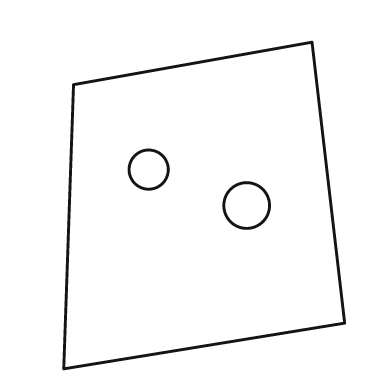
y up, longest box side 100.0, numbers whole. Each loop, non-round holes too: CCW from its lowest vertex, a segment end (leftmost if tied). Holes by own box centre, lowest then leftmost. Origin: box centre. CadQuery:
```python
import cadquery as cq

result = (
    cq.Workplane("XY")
    .moveTo(-43.0, -50.0)
    .lineTo(43.0, -36.0)
    .lineTo(33.0, 50.0)
    .lineTo(-40.0, 37.0)
    .close()
    .moveTo(13.0, 0.0)
    .circle(7.0)
    .moveTo(-17.0, 11.0)
    .circle(6.0)
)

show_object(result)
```